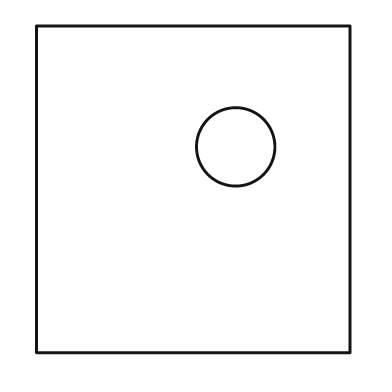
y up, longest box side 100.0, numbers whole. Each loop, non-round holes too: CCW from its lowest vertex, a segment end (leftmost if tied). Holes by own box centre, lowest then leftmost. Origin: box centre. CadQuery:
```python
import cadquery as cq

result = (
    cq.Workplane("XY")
    .moveTo(-48.0, -50.0)
    .lineTo(48.0, -50.0)
    .lineTo(48.0, 50.0)
    .lineTo(-48.0, 50.0)
    .close()
    .moveTo(13.0, 13.0)
    .circle(12.0)
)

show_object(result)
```